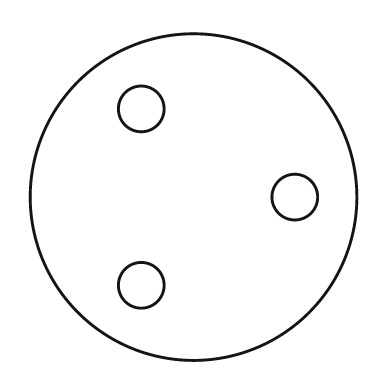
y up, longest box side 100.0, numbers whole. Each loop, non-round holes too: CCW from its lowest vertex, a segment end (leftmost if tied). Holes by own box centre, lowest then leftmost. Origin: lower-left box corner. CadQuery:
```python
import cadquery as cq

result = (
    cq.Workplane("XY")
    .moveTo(50.0, 50.0)
    .circle(50.0)
    .moveTo(34.0, 23.0)
    .circle(7.0)
    .moveTo(81.0, 50.0)
    .circle(7.0)
    .moveTo(34.0, 77.0)
    .circle(7.0)
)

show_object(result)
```